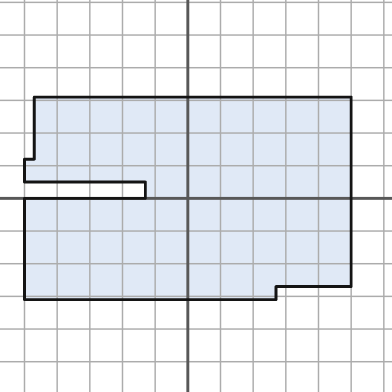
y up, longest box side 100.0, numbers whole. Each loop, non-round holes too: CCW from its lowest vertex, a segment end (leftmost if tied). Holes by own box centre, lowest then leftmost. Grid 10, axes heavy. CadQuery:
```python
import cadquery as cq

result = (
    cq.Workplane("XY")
    .moveTo(-50.0, -31.0)
    .lineTo(27.0, -31.0)
    .lineTo(27.0, -27.0)
    .lineTo(50.0, -27.0)
    .lineTo(50.0, 31.0)
    .lineTo(-47.0, 31.0)
    .lineTo(-47.0, 12.0)
    .lineTo(-50.0, 12.0)
    .lineTo(-50.0, 5.0)
    .lineTo(-13.0, 5.0)
    .lineTo(-13.0, 0.0)
    .lineTo(-50.0, 0.0)
    .close()
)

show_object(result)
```